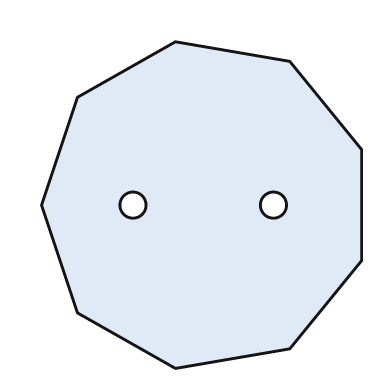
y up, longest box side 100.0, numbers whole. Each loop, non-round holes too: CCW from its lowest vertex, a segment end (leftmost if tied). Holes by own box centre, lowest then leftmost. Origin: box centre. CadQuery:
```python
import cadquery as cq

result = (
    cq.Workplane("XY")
    .moveTo(-8.0, -50.0)
    .lineTo(27.0, -44.0)
    .lineTo(49.0, -17.0)
    .lineTo(49.0, 17.0)
    .lineTo(27.0, 44.0)
    .lineTo(-8.0, 50.0)
    .lineTo(-38.0, 33.0)
    .lineTo(-49.0, 0.0)
    .lineTo(-38.0, -33.0)
    .close()
    .moveTo(-21.0, 0.0)
    .circle(4.0)
    .moveTo(22.0, 0.0)
    .circle(4.0)
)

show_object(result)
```